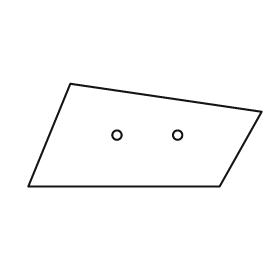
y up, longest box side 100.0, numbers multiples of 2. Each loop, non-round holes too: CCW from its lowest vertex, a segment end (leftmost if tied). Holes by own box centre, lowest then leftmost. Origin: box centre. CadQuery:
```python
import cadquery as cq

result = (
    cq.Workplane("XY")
    .moveTo(-50.0, -22.0)
    .lineTo(32.0, -22.0)
    .lineTo(50.0, 10.0)
    .lineTo(-32.0, 22.0)
    .close()
    .moveTo(-12.0, 0.0)
    .circle(2.0)
    .moveTo(14.0, 0.0)
    .circle(2.0)
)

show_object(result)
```